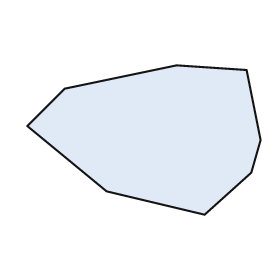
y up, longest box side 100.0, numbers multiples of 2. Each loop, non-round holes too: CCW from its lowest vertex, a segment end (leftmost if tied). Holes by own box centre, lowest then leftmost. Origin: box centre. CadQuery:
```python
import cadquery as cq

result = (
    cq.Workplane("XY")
    .moveTo(26.0, -32.0)
    .lineTo(46.0, -14.0)
    .lineTo(50.0, 0.0)
    .lineTo(44.0, 30.0)
    .lineTo(14.0, 32.0)
    .lineTo(-34.0, 22.0)
    .lineTo(-50.0, 6.0)
    .lineTo(-16.0, -22.0)
    .close()
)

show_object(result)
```